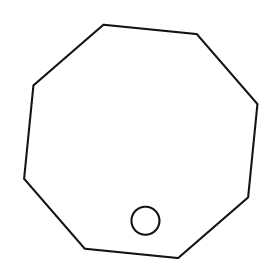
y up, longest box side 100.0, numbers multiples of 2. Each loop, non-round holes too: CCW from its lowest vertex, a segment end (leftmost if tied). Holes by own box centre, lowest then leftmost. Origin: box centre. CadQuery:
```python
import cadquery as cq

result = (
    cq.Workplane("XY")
    .moveTo(16.0, -50.0)
    .lineTo(46.0, -24.0)
    .lineTo(50.0, 16.0)
    .lineTo(24.0, 46.0)
    .lineTo(-16.0, 50.0)
    .lineTo(-46.0, 24.0)
    .lineTo(-50.0, -16.0)
    .lineTo(-24.0, -46.0)
    .close()
    .moveTo(2.0, -34.0)
    .circle(6.0)
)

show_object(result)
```